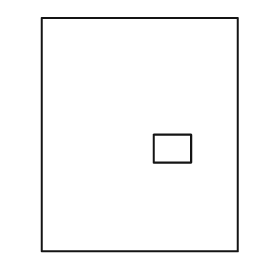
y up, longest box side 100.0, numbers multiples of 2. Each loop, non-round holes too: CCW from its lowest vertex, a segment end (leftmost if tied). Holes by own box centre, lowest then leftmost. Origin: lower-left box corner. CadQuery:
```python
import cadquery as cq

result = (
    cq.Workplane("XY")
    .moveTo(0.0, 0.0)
    .lineTo(84.0, 0.0)
    .lineTo(84.0, 100.0)
    .lineTo(0.0, 100.0)
    .close()
    .moveTo(48.0, 38.0)
    .lineTo(64.0, 38.0)
    .lineTo(64.0, 50.0)
    .lineTo(48.0, 50.0)
    .close()
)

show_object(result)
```